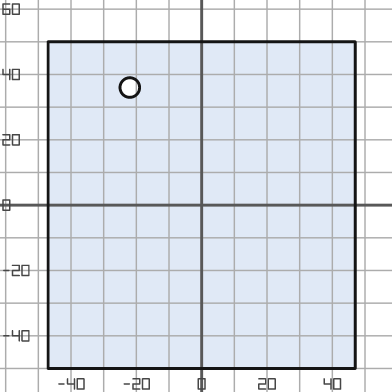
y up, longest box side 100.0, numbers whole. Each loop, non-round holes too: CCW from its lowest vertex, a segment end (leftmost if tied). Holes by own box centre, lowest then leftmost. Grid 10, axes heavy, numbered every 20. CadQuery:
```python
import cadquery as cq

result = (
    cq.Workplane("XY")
    .moveTo(-47.0, -50.0)
    .lineTo(47.0, -50.0)
    .lineTo(47.0, 50.0)
    .lineTo(-47.0, 50.0)
    .close()
    .moveTo(-22.0, 36.0)
    .circle(3.0)
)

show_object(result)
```